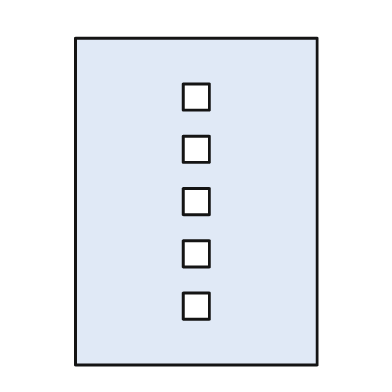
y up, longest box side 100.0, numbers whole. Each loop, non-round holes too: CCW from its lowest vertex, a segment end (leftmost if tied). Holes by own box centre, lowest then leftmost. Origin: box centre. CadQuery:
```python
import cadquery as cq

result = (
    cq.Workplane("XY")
    .moveTo(-37.0, -50.0)
    .lineTo(37.0, -50.0)
    .lineTo(37.0, 50.0)
    .lineTo(-37.0, 50.0)
    .close()
    .moveTo(-4.0, -36.0)
    .lineTo(4.0, -36.0)
    .lineTo(4.0, -28.0)
    .lineTo(-4.0, -28.0)
    .close()
    .moveTo(-4.0, -20.0)
    .lineTo(4.0, -20.0)
    .lineTo(4.0, -12.0)
    .lineTo(-4.0, -12.0)
    .close()
    .moveTo(-4.0, -4.0)
    .lineTo(4.0, -4.0)
    .lineTo(4.0, 4.0)
    .lineTo(-4.0, 4.0)
    .close()
    .moveTo(-4.0, 12.0)
    .lineTo(4.0, 12.0)
    .lineTo(4.0, 20.0)
    .lineTo(-4.0, 20.0)
    .close()
    .moveTo(-4.0, 28.0)
    .lineTo(4.0, 28.0)
    .lineTo(4.0, 36.0)
    .lineTo(-4.0, 36.0)
    .close()
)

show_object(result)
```